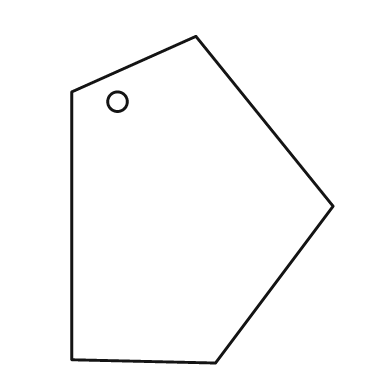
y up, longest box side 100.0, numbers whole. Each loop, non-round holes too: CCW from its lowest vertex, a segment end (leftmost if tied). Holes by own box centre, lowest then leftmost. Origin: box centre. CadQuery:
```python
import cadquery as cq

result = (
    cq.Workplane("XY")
    .moveTo(4.0, -50.0)
    .lineTo(40.0, -2.0)
    .lineTo(-2.0, 50.0)
    .lineTo(-40.0, 33.0)
    .lineTo(-40.0, -49.0)
    .close()
    .moveTo(-26.0, 30.0)
    .circle(3.0)
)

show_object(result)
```